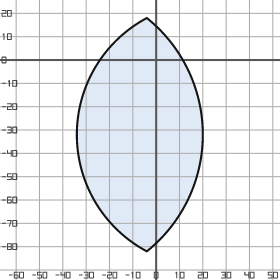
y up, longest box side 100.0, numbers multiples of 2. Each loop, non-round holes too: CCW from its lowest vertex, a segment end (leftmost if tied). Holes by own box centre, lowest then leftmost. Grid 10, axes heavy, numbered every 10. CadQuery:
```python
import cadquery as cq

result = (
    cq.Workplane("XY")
    .moveTo(-4.0, -82.0)
    .threePointArc((20.0, -32.0), (-4.0, 18.0))
    .threePointArc((-34.0, -32.0), (-4.0, -82.0))
    .close()
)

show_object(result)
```